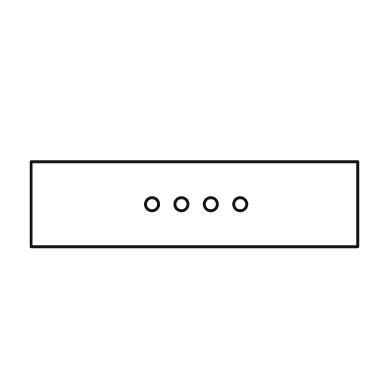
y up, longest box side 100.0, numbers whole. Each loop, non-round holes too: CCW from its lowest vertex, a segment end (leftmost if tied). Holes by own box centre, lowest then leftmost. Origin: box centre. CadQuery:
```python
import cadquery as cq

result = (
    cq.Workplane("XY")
    .moveTo(-50.0, -13.0)
    .lineTo(50.0, -13.0)
    .lineTo(50.0, 13.0)
    .lineTo(-50.0, 13.0)
    .close()
    .moveTo(-13.0, 0.0)
    .circle(2.0)
    .moveTo(-4.0, 0.0)
    .circle(2.0)
    .moveTo(5.0, 0.0)
    .circle(2.0)
    .moveTo(14.0, 0.0)
    .circle(2.0)
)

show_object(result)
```